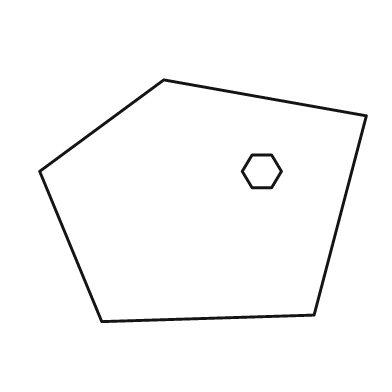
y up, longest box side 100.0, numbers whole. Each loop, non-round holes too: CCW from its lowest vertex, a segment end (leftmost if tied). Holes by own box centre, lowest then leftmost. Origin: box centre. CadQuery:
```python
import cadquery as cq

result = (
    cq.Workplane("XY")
    .moveTo(-31.0, -37.0)
    .lineTo(34.0, -35.0)
    .lineTo(50.0, 26.0)
    .lineTo(-12.0, 37.0)
    .lineTo(-50.0, 9.0)
    .close()
    .moveTo(15.0, 4.0)
    .lineTo(21.0, 4.0)
    .lineTo(24.0, 9.0)
    .lineTo(21.0, 14.0)
    .lineTo(15.0, 14.0)
    .lineTo(12.0, 9.0)
    .close()
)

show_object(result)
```